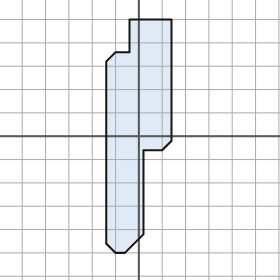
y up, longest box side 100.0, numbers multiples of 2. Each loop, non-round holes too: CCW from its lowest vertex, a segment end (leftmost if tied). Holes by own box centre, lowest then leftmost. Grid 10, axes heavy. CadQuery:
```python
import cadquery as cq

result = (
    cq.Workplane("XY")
    .moveTo(-10.0, -50.0)
    .lineTo(-6.0, -50.0)
    .lineTo(2.0, -42.0)
    .lineTo(2.0, -6.0)
    .lineTo(10.0, -6.0)
    .lineTo(14.0, -2.0)
    .lineTo(14.0, 50.0)
    .lineTo(-4.0, 50.0)
    .lineTo(-4.0, 36.0)
    .lineTo(-10.0, 36.0)
    .lineTo(-14.0, 32.0)
    .lineTo(-14.0, -46.0)
    .close()
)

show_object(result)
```